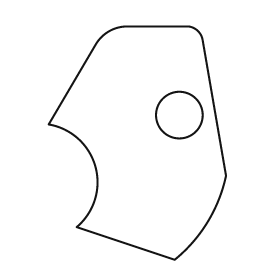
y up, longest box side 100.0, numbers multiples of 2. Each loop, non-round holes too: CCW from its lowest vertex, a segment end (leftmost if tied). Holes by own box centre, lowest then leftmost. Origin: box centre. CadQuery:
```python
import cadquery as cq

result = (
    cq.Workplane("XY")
    .moveTo(16.0, -50.0)
    .threePointArc((30.0, -34.0), (38.0, -14.0))
    .lineTo(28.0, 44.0)
    .threePointArc((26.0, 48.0), (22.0, 50.0))
    .lineTo(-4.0, 50.0)
    .threePointArc((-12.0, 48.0), (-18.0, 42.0))
    .lineTo(-38.0, 8.0)
    .threePointArc((-18.0, -10.0), (-26.0, -36.0))
    .close()
    .moveTo(18.0, 12.0)
    .circle(10.0)
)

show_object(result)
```